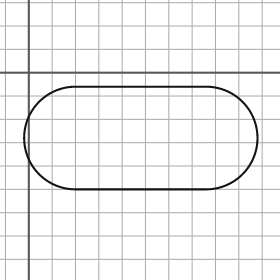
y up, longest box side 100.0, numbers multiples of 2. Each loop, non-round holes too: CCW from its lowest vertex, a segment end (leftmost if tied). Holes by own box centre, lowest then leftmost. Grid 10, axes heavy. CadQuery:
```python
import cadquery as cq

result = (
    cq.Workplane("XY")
    .moveTo(20.0, -50.0)
    .lineTo(76.0, -50.0)
    .threePointArc((98.0, -28.0), (76.0, -6.0))
    .lineTo(20.0, -6.0)
    .threePointArc((-2.0, -28.0), (20.0, -50.0))
    .close()
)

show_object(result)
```